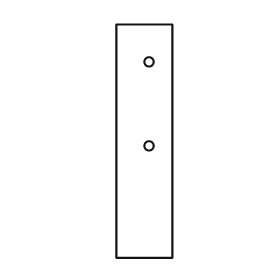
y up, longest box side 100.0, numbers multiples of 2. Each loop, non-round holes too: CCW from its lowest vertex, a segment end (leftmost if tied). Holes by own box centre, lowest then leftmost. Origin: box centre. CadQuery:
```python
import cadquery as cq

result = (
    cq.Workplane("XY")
    .moveTo(-12.0, -50.0)
    .lineTo(12.0, -50.0)
    .lineTo(12.0, 50.0)
    .lineTo(-12.0, 50.0)
    .close()
    .moveTo(2.0, -2.0)
    .circle(2.0)
    .moveTo(2.0, 34.0)
    .circle(2.0)
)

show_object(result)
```